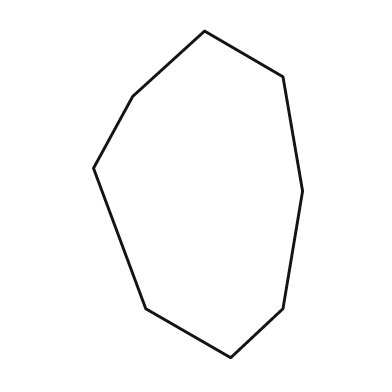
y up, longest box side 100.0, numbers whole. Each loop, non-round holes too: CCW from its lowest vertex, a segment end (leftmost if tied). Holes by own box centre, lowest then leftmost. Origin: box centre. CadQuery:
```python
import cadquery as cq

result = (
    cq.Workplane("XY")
    .moveTo(10.0, -50.0)
    .lineTo(26.0, -35.0)
    .lineTo(32.0, 1.0)
    .lineTo(26.0, 36.0)
    .lineTo(2.0, 50.0)
    .lineTo(-20.0, 30.0)
    .lineTo(-32.0, 8.0)
    .lineTo(-16.0, -35.0)
    .close()
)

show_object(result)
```